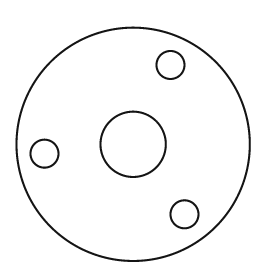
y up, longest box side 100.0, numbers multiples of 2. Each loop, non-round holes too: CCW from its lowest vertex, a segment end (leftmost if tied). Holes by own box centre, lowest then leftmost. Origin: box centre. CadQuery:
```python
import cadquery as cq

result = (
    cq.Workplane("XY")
    .moveTo(0.0, 0.0)
    .circle(50.0)
    .moveTo(22.0, -30.0)
    .circle(6.0)
    .moveTo(-38.0, -4.0)
    .circle(6.0)
    .moveTo(0.0, 0.0)
    .circle(14.0)
    .moveTo(16.0, 34.0)
    .circle(6.0)
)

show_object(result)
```